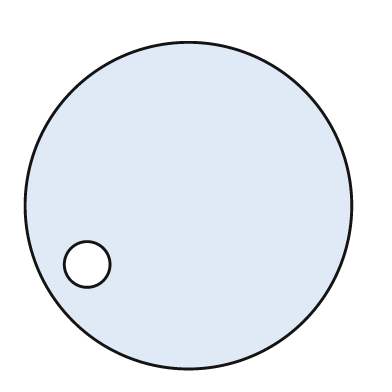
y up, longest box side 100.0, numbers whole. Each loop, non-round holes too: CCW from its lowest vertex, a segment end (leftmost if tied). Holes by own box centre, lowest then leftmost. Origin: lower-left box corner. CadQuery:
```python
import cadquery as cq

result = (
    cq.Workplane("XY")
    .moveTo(50.0, 50.0)
    .circle(50.0)
    .moveTo(19.0, 32.0)
    .circle(7.0)
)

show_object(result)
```